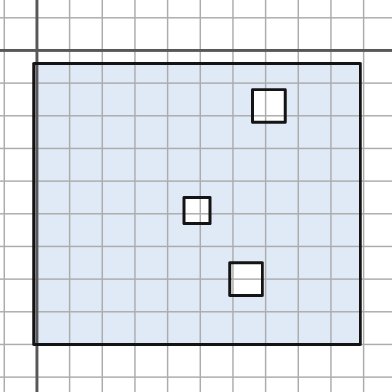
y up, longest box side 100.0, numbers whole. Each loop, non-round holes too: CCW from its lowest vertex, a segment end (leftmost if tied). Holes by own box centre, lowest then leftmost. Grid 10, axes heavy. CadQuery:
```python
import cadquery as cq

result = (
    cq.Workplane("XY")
    .moveTo(-1.0, -90.0)
    .lineTo(99.0, -90.0)
    .lineTo(99.0, -4.0)
    .lineTo(-1.0, -4.0)
    .close()
    .moveTo(59.0, -75.0)
    .lineTo(69.0, -75.0)
    .lineTo(69.0, -65.0)
    .lineTo(59.0, -65.0)
    .close()
    .moveTo(45.0, -53.0)
    .lineTo(53.0, -53.0)
    .lineTo(53.0, -45.0)
    .lineTo(45.0, -45.0)
    .close()
    .moveTo(66.0, -22.0)
    .lineTo(76.0, -22.0)
    .lineTo(76.0, -12.0)
    .lineTo(66.0, -12.0)
    .close()
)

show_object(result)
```